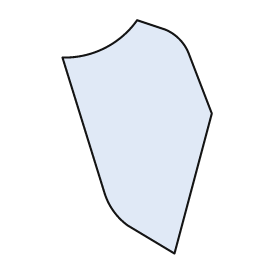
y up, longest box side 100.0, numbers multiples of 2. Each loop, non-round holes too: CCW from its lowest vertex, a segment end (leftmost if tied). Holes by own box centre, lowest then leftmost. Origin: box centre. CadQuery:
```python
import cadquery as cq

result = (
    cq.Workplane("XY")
    .moveTo(16.0, -50.0)
    .lineTo(32.0, 10.0)
    .lineTo(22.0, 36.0)
    .threePointArc((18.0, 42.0), (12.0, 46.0))
    .lineTo(0.0, 50.0)
    .threePointArc((-14.0, 38.0), (-32.0, 34.0))
    .lineTo(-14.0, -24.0)
    .threePointArc((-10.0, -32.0), (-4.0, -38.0))
    .close()
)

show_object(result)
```